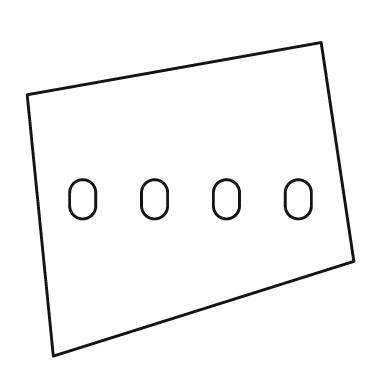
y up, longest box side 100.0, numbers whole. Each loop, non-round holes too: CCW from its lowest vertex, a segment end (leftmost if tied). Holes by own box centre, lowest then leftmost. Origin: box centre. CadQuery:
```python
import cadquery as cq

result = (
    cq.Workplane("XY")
    .moveTo(-42.0, -48.0)
    .lineTo(50.0, -19.0)
    .lineTo(40.0, 48.0)
    .lineTo(-50.0, 32.0)
    .close()
    .moveTo(-37.0, -2.0)
    .threePointArc((-33.0, -6.0), (-29.0, -2.0))
    .lineTo(-29.0, 2.0)
    .threePointArc((-33.0, 6.0), (-37.0, 2.0))
    .close()
    .moveTo(-15.0, -2.0)
    .threePointArc((-11.0, -6.0), (-7.0, -2.0))
    .lineTo(-7.0, 2.0)
    .threePointArc((-11.0, 6.0), (-15.0, 2.0))
    .close()
    .moveTo(7.0, -2.0)
    .threePointArc((11.0, -6.0), (15.0, -2.0))
    .lineTo(15.0, 2.0)
    .threePointArc((11.0, 6.0), (7.0, 2.0))
    .close()
    .moveTo(29.0, -2.0)
    .threePointArc((33.0, -6.0), (37.0, -2.0))
    .lineTo(37.0, 2.0)
    .threePointArc((33.0, 6.0), (29.0, 2.0))
    .close()
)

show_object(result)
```